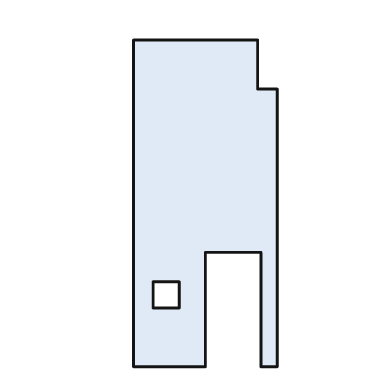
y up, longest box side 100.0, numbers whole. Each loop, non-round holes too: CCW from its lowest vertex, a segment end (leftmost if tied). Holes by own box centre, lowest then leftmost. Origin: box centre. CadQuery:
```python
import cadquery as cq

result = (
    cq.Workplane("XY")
    .moveTo(-22.0, -50.0)
    .lineTo(0.0, -50.0)
    .lineTo(0.0, -15.0)
    .lineTo(17.0, -15.0)
    .lineTo(17.0, -50.0)
    .lineTo(22.0, -50.0)
    .lineTo(22.0, 35.0)
    .lineTo(16.0, 35.0)
    .lineTo(16.0, 50.0)
    .lineTo(-22.0, 50.0)
    .close()
    .moveTo(-16.0, -32.0)
    .lineTo(-8.0, -32.0)
    .lineTo(-8.0, -24.0)
    .lineTo(-16.0, -24.0)
    .close()
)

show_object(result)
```